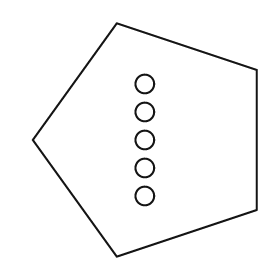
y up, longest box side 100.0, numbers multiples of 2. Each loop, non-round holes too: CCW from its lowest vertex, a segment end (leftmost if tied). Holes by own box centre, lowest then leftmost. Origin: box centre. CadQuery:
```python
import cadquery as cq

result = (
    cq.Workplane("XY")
    .moveTo(-12.0, -50.0)
    .lineTo(48.0, -30.0)
    .lineTo(48.0, 30.0)
    .lineTo(-12.0, 50.0)
    .lineTo(-48.0, 0.0)
    .close()
    .moveTo(0.0, -24.0)
    .circle(4.0)
    .moveTo(0.0, -12.0)
    .circle(4.0)
    .moveTo(0.0, 0.0)
    .circle(4.0)
    .moveTo(0.0, 12.0)
    .circle(4.0)
    .moveTo(0.0, 24.0)
    .circle(4.0)
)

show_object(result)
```